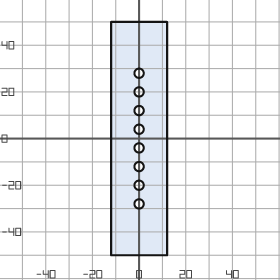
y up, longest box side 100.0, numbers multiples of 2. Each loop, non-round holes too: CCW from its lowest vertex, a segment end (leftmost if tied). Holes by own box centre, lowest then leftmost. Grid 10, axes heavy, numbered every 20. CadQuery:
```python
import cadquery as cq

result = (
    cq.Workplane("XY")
    .moveTo(-12.0, -50.0)
    .lineTo(12.0, -50.0)
    .lineTo(12.0, 50.0)
    .lineTo(-12.0, 50.0)
    .close()
    .moveTo(0.0, -28.0)
    .circle(2.0)
    .moveTo(0.0, -20.0)
    .circle(2.0)
    .moveTo(0.0, -12.0)
    .circle(2.0)
    .moveTo(0.0, -4.0)
    .circle(2.0)
    .moveTo(0.0, 4.0)
    .circle(2.0)
    .moveTo(0.0, 12.0)
    .circle(2.0)
    .moveTo(0.0, 20.0)
    .circle(2.0)
    .moveTo(0.0, 28.0)
    .circle(2.0)
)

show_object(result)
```